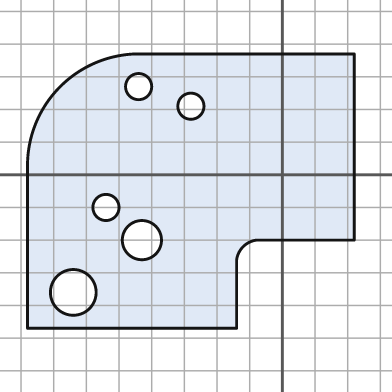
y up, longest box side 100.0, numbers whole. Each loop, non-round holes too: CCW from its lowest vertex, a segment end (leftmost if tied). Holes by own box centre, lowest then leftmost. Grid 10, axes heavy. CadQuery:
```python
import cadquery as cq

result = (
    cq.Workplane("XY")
    .moveTo(-78.0, -47.0)
    .lineTo(-14.0, -47.0)
    .lineTo(-14.0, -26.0)
    .threePointArc((-12.0, -22.0), (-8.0, -20.0))
    .lineTo(22.0, -20.0)
    .lineTo(22.0, 37.0)
    .lineTo(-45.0, 37.0)
    .threePointArc((-68.0, 27.0), (-78.0, 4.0))
    .close()
    .moveTo(-64.0, -36.0)
    .circle(7.0)
    .moveTo(-43.0, -20.0)
    .circle(6.0)
    .moveTo(-54.0, -10.0)
    .circle(4.0)
    .moveTo(-28.0, 21.0)
    .circle(4.0)
    .moveTo(-44.0, 27.0)
    .circle(4.0)
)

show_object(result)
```